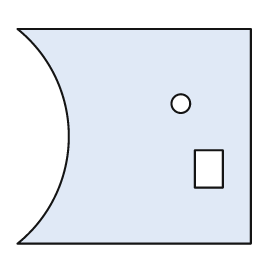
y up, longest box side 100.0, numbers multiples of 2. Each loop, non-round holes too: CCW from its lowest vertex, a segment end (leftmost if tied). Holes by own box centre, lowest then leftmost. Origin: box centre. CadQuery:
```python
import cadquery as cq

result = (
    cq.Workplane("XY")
    .moveTo(-50.0, -46.0)
    .lineTo(50.0, -46.0)
    .lineTo(50.0, 46.0)
    .lineTo(-50.0, 46.0)
    .threePointArc((-28.0, 0.0), (-50.0, -46.0))
    .close()
    .moveTo(26.0, -22.0)
    .lineTo(38.0, -22.0)
    .lineTo(38.0, -6.0)
    .lineTo(26.0, -6.0)
    .close()
    .moveTo(20.0, 14.0)
    .circle(4.0)
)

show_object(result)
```